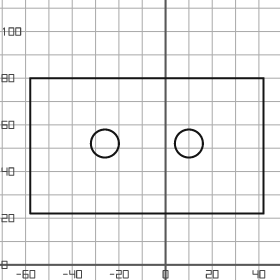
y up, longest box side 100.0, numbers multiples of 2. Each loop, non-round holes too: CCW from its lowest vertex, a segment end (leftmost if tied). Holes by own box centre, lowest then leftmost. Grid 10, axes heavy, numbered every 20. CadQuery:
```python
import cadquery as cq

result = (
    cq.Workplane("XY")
    .moveTo(-58.0, 22.0)
    .lineTo(42.0, 22.0)
    .lineTo(42.0, 80.0)
    .lineTo(-58.0, 80.0)
    .close()
    .moveTo(-26.0, 52.0)
    .circle(6.0)
    .moveTo(10.0, 52.0)
    .circle(6.0)
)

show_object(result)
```